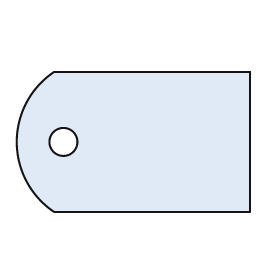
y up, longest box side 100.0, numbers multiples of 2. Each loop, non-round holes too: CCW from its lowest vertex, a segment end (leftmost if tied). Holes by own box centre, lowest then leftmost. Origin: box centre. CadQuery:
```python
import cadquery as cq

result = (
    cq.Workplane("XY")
    .moveTo(-34.0, -30.0)
    .lineTo(50.0, -30.0)
    .lineTo(50.0, 30.0)
    .lineTo(-34.0, 30.0)
    .threePointArc((-50.0, 0.0), (-34.0, -30.0))
    .close()
    .moveTo(-30.0, 0.0)
    .circle(6.0)
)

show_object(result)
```